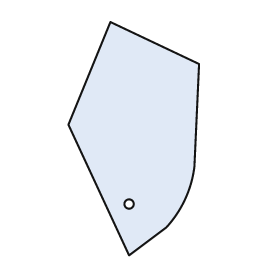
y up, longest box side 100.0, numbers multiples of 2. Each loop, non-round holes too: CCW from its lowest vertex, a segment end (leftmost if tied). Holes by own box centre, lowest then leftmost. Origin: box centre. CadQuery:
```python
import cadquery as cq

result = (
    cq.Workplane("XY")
    .moveTo(-2.0, -50.0)
    .lineTo(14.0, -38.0)
    .threePointArc((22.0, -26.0), (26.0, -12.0))
    .lineTo(28.0, 32.0)
    .lineTo(-10.0, 50.0)
    .lineTo(-28.0, 6.0)
    .close()
    .moveTo(-2.0, -28.0)
    .circle(2.0)
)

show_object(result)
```